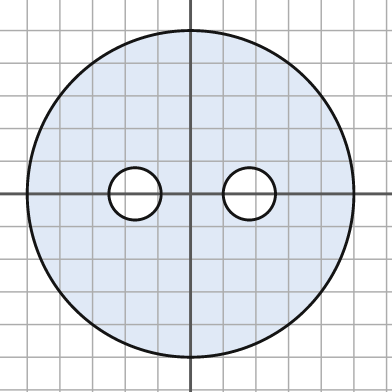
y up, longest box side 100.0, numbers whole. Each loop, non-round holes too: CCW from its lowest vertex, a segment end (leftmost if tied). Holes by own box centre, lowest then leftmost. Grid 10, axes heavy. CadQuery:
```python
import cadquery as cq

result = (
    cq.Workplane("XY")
    .moveTo(0.0, 0.0)
    .circle(50.0)
    .moveTo(-17.0, 0.0)
    .circle(8.0)
    .moveTo(18.0, 0.0)
    .circle(8.0)
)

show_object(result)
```